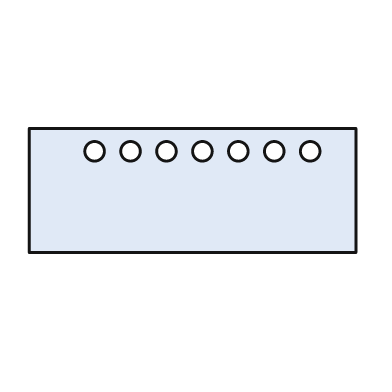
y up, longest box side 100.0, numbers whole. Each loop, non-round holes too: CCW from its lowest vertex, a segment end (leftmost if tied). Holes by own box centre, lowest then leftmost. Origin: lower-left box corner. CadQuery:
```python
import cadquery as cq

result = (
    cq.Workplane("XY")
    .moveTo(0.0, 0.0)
    .lineTo(100.0, 0.0)
    .lineTo(100.0, 38.0)
    .lineTo(0.0, 38.0)
    .close()
    .moveTo(20.0, 31.0)
    .circle(3.0)
    .moveTo(31.0, 31.0)
    .circle(3.0)
    .moveTo(42.0, 31.0)
    .circle(3.0)
    .moveTo(53.0, 31.0)
    .circle(3.0)
    .moveTo(64.0, 31.0)
    .circle(3.0)
    .moveTo(75.0, 31.0)
    .circle(3.0)
    .moveTo(86.0, 31.0)
    .circle(3.0)
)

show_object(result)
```